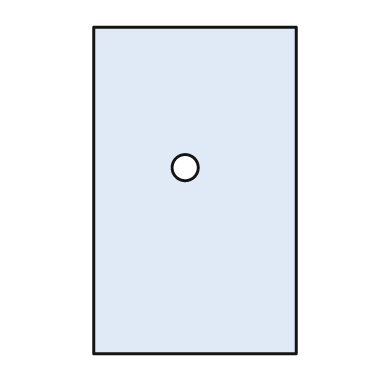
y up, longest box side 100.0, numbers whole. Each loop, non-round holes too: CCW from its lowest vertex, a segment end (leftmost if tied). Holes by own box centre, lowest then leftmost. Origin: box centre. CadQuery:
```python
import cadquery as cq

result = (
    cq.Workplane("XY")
    .moveTo(-31.0, -50.0)
    .lineTo(31.0, -50.0)
    .lineTo(31.0, 50.0)
    .lineTo(-31.0, 50.0)
    .close()
    .moveTo(-3.0, 7.0)
    .circle(4.0)
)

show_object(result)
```